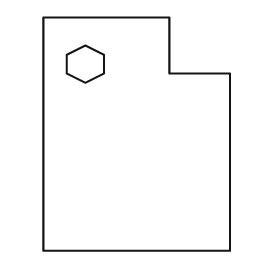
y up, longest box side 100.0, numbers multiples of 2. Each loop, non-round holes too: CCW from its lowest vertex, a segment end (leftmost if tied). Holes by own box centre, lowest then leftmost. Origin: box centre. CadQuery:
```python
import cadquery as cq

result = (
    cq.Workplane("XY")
    .moveTo(-40.0, -50.0)
    .lineTo(40.0, -50.0)
    .lineTo(40.0, 26.0)
    .lineTo(14.0, 26.0)
    .lineTo(14.0, 50.0)
    .lineTo(-40.0, 50.0)
    .close()
    .moveTo(-22.0, 22.0)
    .lineTo(-14.0, 26.0)
    .lineTo(-14.0, 34.0)
    .lineTo(-22.0, 38.0)
    .lineTo(-30.0, 34.0)
    .lineTo(-30.0, 26.0)
    .close()
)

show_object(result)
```